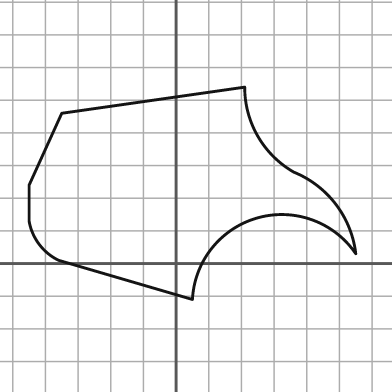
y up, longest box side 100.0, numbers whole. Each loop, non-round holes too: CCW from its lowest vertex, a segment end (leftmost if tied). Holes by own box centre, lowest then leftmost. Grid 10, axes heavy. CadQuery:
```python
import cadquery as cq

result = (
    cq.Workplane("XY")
    .moveTo(5.0, -11.0)
    .threePointArc((25.0, 14.0), (55.0, 3.0))
    .threePointArc((49.0, 18.0), (36.0, 28.0))
    .threePointArc((25.0, 39.0), (21.0, 54.0))
    .lineTo(-35.0, 46.0)
    .lineTo(-45.0, 24.0)
    .lineTo(-45.0, 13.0)
    .threePointArc((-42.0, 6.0), (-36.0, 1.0))
    .close()
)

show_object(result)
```